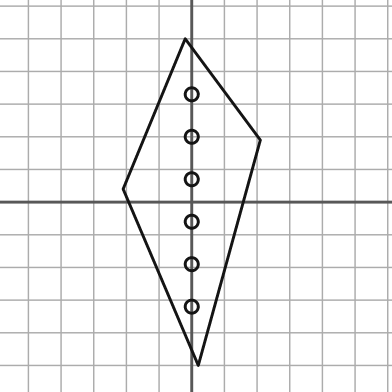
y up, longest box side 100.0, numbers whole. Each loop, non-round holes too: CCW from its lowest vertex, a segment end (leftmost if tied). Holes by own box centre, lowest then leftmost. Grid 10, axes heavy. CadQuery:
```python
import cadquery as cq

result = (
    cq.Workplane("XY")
    .moveTo(2.0, -50.0)
    .lineTo(21.0, 19.0)
    .lineTo(-2.0, 50.0)
    .lineTo(-21.0, 4.0)
    .close()
    .moveTo(0.0, -32.0)
    .circle(2.0)
    .moveTo(0.0, -19.0)
    .circle(2.0)
    .moveTo(0.0, -6.0)
    .circle(2.0)
    .moveTo(0.0, 7.0)
    .circle(2.0)
    .moveTo(0.0, 20.0)
    .circle(2.0)
    .moveTo(0.0, 33.0)
    .circle(2.0)
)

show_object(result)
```